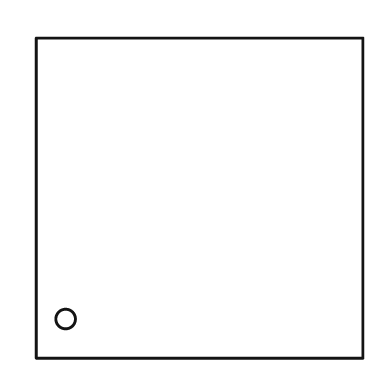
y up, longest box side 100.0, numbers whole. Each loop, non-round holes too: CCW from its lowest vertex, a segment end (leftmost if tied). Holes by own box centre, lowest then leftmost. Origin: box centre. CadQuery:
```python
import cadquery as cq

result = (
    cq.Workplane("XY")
    .moveTo(-50.0, -49.0)
    .lineTo(50.0, -49.0)
    .lineTo(50.0, 49.0)
    .lineTo(-50.0, 49.0)
    .close()
    .moveTo(-41.0, -37.0)
    .circle(3.0)
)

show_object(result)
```